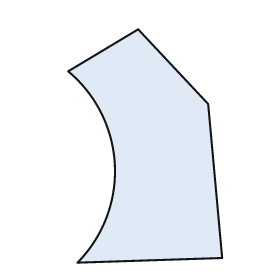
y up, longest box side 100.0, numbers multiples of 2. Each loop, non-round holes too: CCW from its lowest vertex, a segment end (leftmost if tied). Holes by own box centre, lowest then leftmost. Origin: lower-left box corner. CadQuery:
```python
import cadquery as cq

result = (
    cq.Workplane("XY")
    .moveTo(4.0, 0.0)
    .lineTo(66.0, 2.0)
    .lineTo(60.0, 68.0)
    .lineTo(30.0, 100.0)
    .lineTo(0.0, 82.0)
    .threePointArc((20.0, 42.0), (4.0, 0.0))
    .close()
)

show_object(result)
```